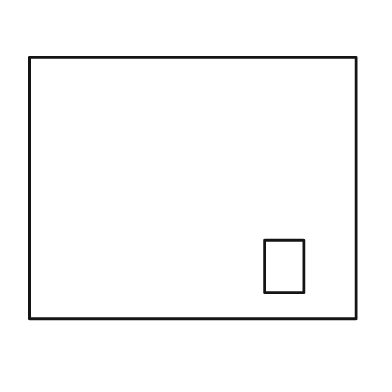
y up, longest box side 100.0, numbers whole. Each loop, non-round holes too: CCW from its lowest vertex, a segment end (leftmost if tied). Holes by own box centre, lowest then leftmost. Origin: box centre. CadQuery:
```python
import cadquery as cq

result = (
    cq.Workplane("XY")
    .moveTo(-50.0, -40.0)
    .lineTo(50.0, -40.0)
    .lineTo(50.0, 40.0)
    .lineTo(-50.0, 40.0)
    .close()
    .moveTo(22.0, -32.0)
    .lineTo(34.0, -32.0)
    .lineTo(34.0, -16.0)
    .lineTo(22.0, -16.0)
    .close()
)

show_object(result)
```